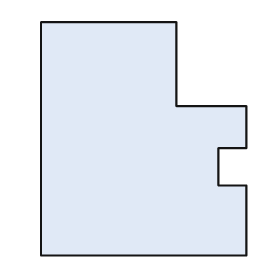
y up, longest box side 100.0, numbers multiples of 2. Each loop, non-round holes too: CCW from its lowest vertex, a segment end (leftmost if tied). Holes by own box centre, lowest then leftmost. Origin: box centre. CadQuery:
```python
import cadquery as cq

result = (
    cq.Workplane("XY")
    .moveTo(-44.0, -50.0)
    .lineTo(44.0, -50.0)
    .lineTo(44.0, -20.0)
    .lineTo(32.0, -20.0)
    .lineTo(32.0, -4.0)
    .lineTo(44.0, -4.0)
    .lineTo(44.0, 14.0)
    .lineTo(14.0, 14.0)
    .lineTo(14.0, 50.0)
    .lineTo(-44.0, 50.0)
    .close()
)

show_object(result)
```